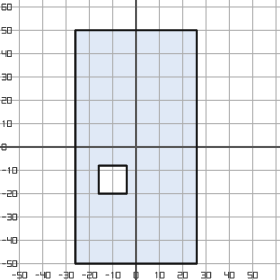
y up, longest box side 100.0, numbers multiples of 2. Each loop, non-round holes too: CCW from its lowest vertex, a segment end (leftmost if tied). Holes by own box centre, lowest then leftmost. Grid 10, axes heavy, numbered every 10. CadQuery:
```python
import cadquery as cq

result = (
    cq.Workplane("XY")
    .moveTo(-26.0, -50.0)
    .lineTo(26.0, -50.0)
    .lineTo(26.0, 50.0)
    .lineTo(-26.0, 50.0)
    .close()
    .moveTo(-16.0, -20.0)
    .lineTo(-4.0, -20.0)
    .lineTo(-4.0, -8.0)
    .lineTo(-16.0, -8.0)
    .close()
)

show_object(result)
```